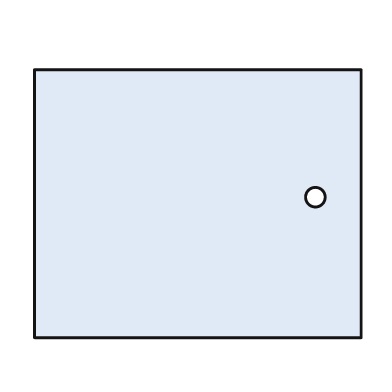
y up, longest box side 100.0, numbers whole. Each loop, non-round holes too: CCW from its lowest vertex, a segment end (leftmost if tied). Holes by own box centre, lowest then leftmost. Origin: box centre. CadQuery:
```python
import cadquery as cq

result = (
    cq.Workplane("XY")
    .moveTo(-50.0, -41.0)
    .lineTo(50.0, -41.0)
    .lineTo(50.0, 41.0)
    .lineTo(-50.0, 41.0)
    .close()
    .moveTo(36.0, 2.0)
    .circle(3.0)
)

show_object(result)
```